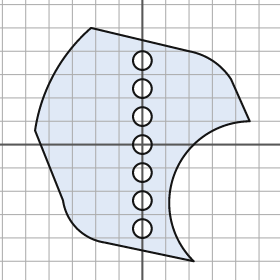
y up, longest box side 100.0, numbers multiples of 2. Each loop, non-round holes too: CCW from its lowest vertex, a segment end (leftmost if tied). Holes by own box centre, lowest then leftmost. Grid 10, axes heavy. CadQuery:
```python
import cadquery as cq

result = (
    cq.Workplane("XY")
    .moveTo(22.0, -50.0)
    .threePointArc((14.0, -12.0), (46.0, 10.0))
    .lineTo(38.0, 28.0)
    .threePointArc((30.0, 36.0), (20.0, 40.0))
    .lineTo(-22.0, 50.0)
    .threePointArc((-38.0, 30.0), (-46.0, 6.0))
    .lineTo(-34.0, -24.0)
    .threePointArc((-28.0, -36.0), (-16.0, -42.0))
    .close()
    .moveTo(0.0, -36.0)
    .circle(4.0)
    .moveTo(0.0, -24.0)
    .circle(4.0)
    .moveTo(0.0, -12.0)
    .circle(4.0)
    .moveTo(0.0, 0.0)
    .circle(4.0)
    .moveTo(0.0, 12.0)
    .circle(4.0)
    .moveTo(0.0, 24.0)
    .circle(4.0)
    .moveTo(0.0, 36.0)
    .circle(4.0)
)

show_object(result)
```